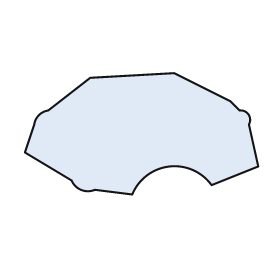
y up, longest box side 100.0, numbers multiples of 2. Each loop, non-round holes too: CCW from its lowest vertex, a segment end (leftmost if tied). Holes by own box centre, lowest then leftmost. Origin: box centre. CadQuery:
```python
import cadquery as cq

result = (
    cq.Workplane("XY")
    .moveTo(-4.0, -26.0)
    .threePointArc((12.0, -14.0), (30.0, -22.0))
    .lineTo(50.0, -14.0)
    .lineTo(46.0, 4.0)
    .threePointArc((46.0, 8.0), (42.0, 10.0))
    .lineTo(38.0, 14.0)
    .lineTo(14.0, 26.0)
    .lineTo(-22.0, 24.0)
    .lineTo(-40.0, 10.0)
    .threePointArc((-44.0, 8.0), (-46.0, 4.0))
    .lineTo(-50.0, -8.0)
    .lineTo(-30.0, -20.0)
    .threePointArc((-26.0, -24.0), (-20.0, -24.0))
    .close()
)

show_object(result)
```